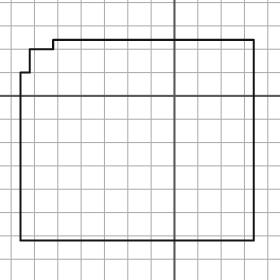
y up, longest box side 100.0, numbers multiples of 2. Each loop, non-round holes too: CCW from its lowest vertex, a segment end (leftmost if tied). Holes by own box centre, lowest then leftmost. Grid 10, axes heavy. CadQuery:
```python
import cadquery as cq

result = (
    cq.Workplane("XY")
    .moveTo(-66.0, -62.0)
    .lineTo(34.0, -62.0)
    .lineTo(34.0, 24.0)
    .lineTo(-52.0, 24.0)
    .lineTo(-52.0, 20.0)
    .lineTo(-62.0, 20.0)
    .lineTo(-62.0, 10.0)
    .lineTo(-66.0, 10.0)
    .close()
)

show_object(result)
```